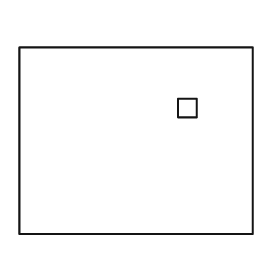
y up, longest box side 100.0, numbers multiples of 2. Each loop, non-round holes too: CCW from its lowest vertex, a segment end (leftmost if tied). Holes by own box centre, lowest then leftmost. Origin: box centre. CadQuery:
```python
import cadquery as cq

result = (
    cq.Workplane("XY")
    .moveTo(-50.0, -40.0)
    .lineTo(50.0, -40.0)
    .lineTo(50.0, 40.0)
    .lineTo(-50.0, 40.0)
    .close()
    .moveTo(18.0, 10.0)
    .lineTo(26.0, 10.0)
    .lineTo(26.0, 18.0)
    .lineTo(18.0, 18.0)
    .close()
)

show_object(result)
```